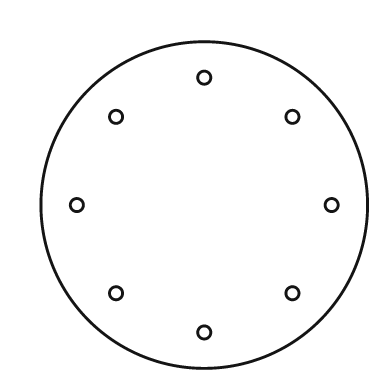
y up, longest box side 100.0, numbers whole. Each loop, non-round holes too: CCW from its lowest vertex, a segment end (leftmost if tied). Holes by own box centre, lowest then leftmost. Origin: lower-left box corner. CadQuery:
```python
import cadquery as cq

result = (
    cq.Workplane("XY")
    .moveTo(50.0, 50.0)
    .circle(50.0)
    .moveTo(50.0, 11.0)
    .circle(2.0)
    .moveTo(23.0, 23.0)
    .circle(2.0)
    .moveTo(77.0, 23.0)
    .circle(2.0)
    .moveTo(11.0, 50.0)
    .circle(2.0)
    .moveTo(89.0, 50.0)
    .circle(2.0)
    .moveTo(23.0, 77.0)
    .circle(2.0)
    .moveTo(77.0, 77.0)
    .circle(2.0)
    .moveTo(50.0, 89.0)
    .circle(2.0)
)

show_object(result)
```